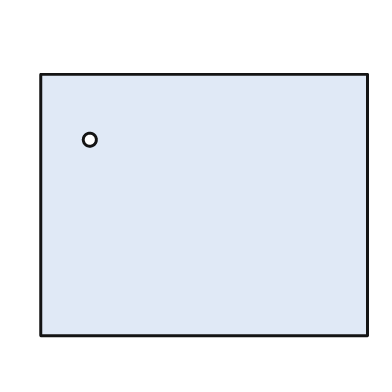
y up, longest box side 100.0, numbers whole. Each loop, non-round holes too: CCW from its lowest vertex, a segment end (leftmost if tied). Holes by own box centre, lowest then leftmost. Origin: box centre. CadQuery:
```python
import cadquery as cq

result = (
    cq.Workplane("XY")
    .moveTo(-50.0, -40.0)
    .lineTo(50.0, -40.0)
    .lineTo(50.0, 40.0)
    .lineTo(-50.0, 40.0)
    .close()
    .moveTo(-35.0, 20.0)
    .circle(2.0)
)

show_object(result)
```